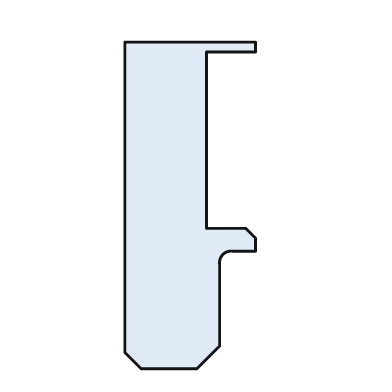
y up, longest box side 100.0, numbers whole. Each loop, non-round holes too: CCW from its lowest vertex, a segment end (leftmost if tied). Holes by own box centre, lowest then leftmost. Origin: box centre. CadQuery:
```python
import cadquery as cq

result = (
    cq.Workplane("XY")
    .moveTo(-15.0, -50.0)
    .lineTo(2.0, -50.0)
    .lineTo(9.0, -43.0)
    .lineTo(9.0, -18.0)
    .threePointArc((10.0, -15.0), (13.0, -14.0))
    .lineTo(20.0, -14.0)
    .lineTo(20.0, -10.0)
    .lineTo(17.0, -7.0)
    .lineTo(5.0, -7.0)
    .lineTo(5.0, 47.0)
    .lineTo(20.0, 47.0)
    .lineTo(20.0, 50.0)
    .lineTo(-20.0, 50.0)
    .lineTo(-20.0, -45.0)
    .close()
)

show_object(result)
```